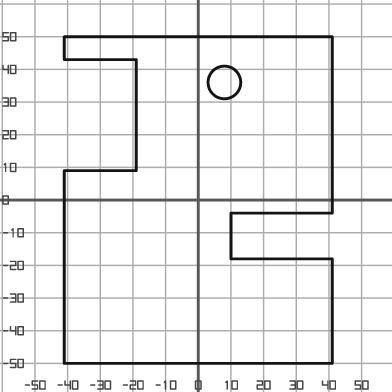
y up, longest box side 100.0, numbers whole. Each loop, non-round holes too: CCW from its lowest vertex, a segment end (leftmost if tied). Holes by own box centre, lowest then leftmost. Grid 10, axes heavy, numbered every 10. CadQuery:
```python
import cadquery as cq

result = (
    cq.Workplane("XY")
    .moveTo(-41.0, -50.0)
    .lineTo(41.0, -50.0)
    .lineTo(41.0, -18.0)
    .lineTo(10.0, -18.0)
    .lineTo(10.0, -4.0)
    .lineTo(41.0, -4.0)
    .lineTo(41.0, 50.0)
    .lineTo(-41.0, 50.0)
    .lineTo(-41.0, 43.0)
    .lineTo(-19.0, 43.0)
    .lineTo(-19.0, 9.0)
    .lineTo(-41.0, 9.0)
    .close()
    .moveTo(8.0, 36.0)
    .circle(5.0)
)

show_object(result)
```